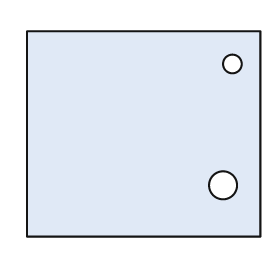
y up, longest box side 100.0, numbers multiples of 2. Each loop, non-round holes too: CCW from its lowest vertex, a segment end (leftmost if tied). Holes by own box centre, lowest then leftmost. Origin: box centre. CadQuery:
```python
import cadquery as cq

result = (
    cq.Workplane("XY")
    .moveTo(-50.0, -44.0)
    .lineTo(50.0, -44.0)
    .lineTo(50.0, 44.0)
    .lineTo(-50.0, 44.0)
    .close()
    .moveTo(34.0, -22.0)
    .circle(6.0)
    .moveTo(38.0, 30.0)
    .circle(4.0)
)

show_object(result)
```